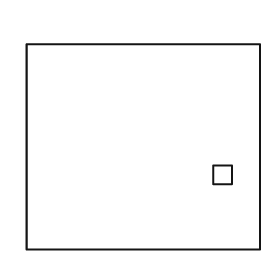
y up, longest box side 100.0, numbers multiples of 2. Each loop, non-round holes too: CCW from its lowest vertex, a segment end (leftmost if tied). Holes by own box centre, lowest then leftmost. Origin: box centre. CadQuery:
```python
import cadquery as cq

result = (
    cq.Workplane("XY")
    .moveTo(-50.0, -44.0)
    .lineTo(50.0, -44.0)
    .lineTo(50.0, 44.0)
    .lineTo(-50.0, 44.0)
    .close()
    .moveTo(30.0, -16.0)
    .lineTo(38.0, -16.0)
    .lineTo(38.0, -8.0)
    .lineTo(30.0, -8.0)
    .close()
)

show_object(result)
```